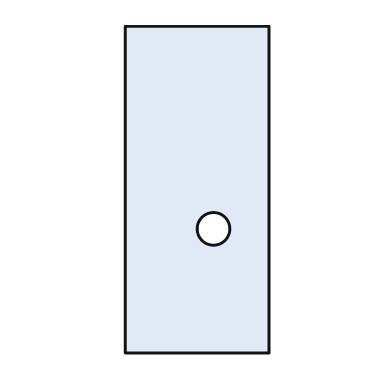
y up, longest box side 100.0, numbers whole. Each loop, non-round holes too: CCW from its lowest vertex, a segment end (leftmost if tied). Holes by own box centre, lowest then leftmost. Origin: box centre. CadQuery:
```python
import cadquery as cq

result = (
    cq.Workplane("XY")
    .moveTo(-22.0, -50.0)
    .lineTo(22.0, -50.0)
    .lineTo(22.0, 50.0)
    .lineTo(-22.0, 50.0)
    .close()
    .moveTo(5.0, -12.0)
    .circle(5.0)
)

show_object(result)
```